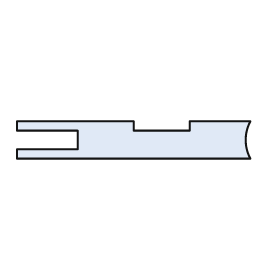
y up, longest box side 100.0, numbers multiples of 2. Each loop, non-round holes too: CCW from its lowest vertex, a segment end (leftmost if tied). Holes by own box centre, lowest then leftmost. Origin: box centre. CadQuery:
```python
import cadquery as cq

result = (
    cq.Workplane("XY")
    .moveTo(-50.0, -8.0)
    .lineTo(50.0, -8.0)
    .threePointArc((48.0, 0.0), (50.0, 8.0))
    .lineTo(24.0, 8.0)
    .lineTo(24.0, 4.0)
    .lineTo(0.0, 4.0)
    .lineTo(0.0, 8.0)
    .lineTo(-50.0, 8.0)
    .lineTo(-50.0, 4.0)
    .lineTo(-24.0, 4.0)
    .lineTo(-24.0, -4.0)
    .lineTo(-50.0, -4.0)
    .close()
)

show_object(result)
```